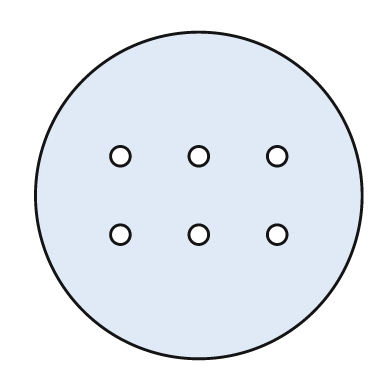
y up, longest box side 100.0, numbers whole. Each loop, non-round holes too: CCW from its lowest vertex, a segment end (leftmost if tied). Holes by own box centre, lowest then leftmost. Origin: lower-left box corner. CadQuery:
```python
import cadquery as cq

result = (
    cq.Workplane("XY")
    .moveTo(50.0, 50.0)
    .circle(50.0)
    .moveTo(26.0, 38.0)
    .circle(3.0)
    .moveTo(50.0, 38.0)
    .circle(3.0)
    .moveTo(74.0, 38.0)
    .circle(3.0)
    .moveTo(26.0, 62.0)
    .circle(3.0)
    .moveTo(50.0, 62.0)
    .circle(3.0)
    .moveTo(74.0, 62.0)
    .circle(3.0)
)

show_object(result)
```